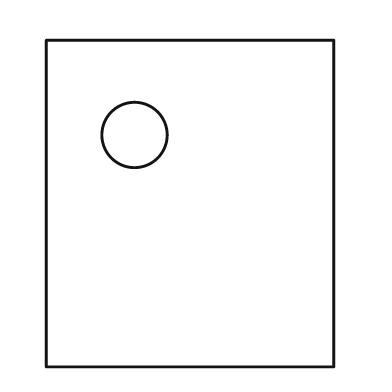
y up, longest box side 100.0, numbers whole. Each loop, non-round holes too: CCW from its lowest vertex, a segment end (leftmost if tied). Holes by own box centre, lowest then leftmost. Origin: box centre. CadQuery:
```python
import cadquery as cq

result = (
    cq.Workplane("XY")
    .moveTo(-44.0, -50.0)
    .lineTo(44.0, -50.0)
    .lineTo(44.0, 50.0)
    .lineTo(-44.0, 50.0)
    .close()
    .moveTo(-17.0, 21.0)
    .circle(10.0)
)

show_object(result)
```